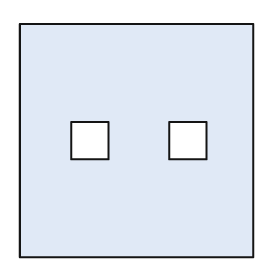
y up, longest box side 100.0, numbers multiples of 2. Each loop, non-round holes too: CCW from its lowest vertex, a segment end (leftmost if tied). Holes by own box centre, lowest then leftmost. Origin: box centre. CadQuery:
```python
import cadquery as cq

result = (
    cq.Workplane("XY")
    .moveTo(-50.0, -50.0)
    .lineTo(50.0, -50.0)
    .lineTo(50.0, 50.0)
    .lineTo(-50.0, 50.0)
    .close()
    .moveTo(-28.0, -8.0)
    .lineTo(-12.0, -8.0)
    .lineTo(-12.0, 8.0)
    .lineTo(-28.0, 8.0)
    .close()
    .moveTo(14.0, -8.0)
    .lineTo(30.0, -8.0)
    .lineTo(30.0, 8.0)
    .lineTo(14.0, 8.0)
    .close()
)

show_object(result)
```